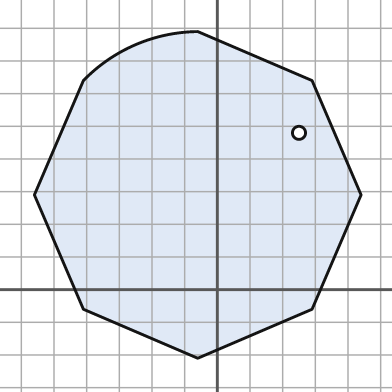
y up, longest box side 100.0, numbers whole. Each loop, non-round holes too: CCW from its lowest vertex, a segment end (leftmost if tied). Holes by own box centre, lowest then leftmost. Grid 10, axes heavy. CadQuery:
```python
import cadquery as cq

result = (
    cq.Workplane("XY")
    .moveTo(-6.0, -21.0)
    .lineTo(29.0, -6.0)
    .lineTo(44.0, 29.0)
    .lineTo(29.0, 64.0)
    .lineTo(-6.0, 79.0)
    .threePointArc((-25.0, 75.0), (-41.0, 64.0))
    .lineTo(-56.0, 29.0)
    .lineTo(-41.0, -6.0)
    .close()
    .moveTo(25.0, 48.0)
    .circle(2.0)
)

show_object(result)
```